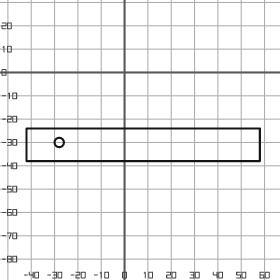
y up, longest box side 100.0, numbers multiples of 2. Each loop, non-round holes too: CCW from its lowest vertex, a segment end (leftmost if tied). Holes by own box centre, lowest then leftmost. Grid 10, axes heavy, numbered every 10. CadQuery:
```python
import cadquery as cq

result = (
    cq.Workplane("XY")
    .moveTo(-42.0, -38.0)
    .lineTo(58.0, -38.0)
    .lineTo(58.0, -24.0)
    .lineTo(-42.0, -24.0)
    .close()
    .moveTo(-28.0, -30.0)
    .circle(2.0)
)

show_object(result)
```